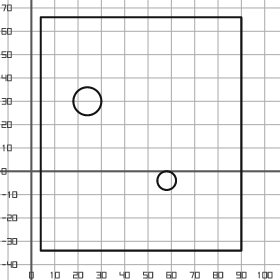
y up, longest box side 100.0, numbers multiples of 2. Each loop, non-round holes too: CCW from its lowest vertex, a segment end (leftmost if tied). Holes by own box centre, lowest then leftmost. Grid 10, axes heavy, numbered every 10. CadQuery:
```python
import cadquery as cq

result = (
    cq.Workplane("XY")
    .moveTo(4.0, -34.0)
    .lineTo(90.0, -34.0)
    .lineTo(90.0, 66.0)
    .lineTo(4.0, 66.0)
    .close()
    .moveTo(58.0, -4.0)
    .circle(4.0)
    .moveTo(24.0, 30.0)
    .circle(6.0)
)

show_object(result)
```